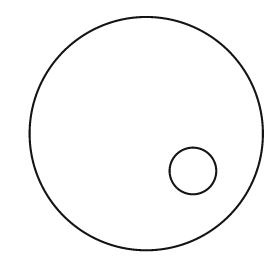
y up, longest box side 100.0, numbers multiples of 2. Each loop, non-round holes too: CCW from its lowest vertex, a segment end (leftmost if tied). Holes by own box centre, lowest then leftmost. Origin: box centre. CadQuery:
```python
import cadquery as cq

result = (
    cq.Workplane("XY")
    .moveTo(0.0, 0.0)
    .circle(50.0)
    .moveTo(20.0, -16.0)
    .circle(10.0)
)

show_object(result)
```